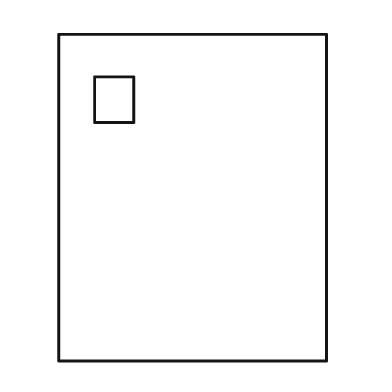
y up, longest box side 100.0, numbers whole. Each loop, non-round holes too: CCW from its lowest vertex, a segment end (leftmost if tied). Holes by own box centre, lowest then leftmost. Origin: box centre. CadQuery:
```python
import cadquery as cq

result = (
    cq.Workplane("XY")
    .moveTo(-41.0, -50.0)
    .lineTo(41.0, -50.0)
    .lineTo(41.0, 50.0)
    .lineTo(-41.0, 50.0)
    .close()
    .moveTo(-30.0, 23.0)
    .lineTo(-18.0, 23.0)
    .lineTo(-18.0, 37.0)
    .lineTo(-30.0, 37.0)
    .close()
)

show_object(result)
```